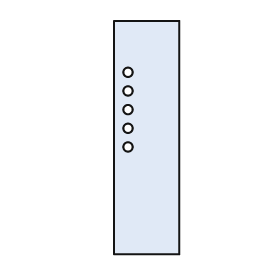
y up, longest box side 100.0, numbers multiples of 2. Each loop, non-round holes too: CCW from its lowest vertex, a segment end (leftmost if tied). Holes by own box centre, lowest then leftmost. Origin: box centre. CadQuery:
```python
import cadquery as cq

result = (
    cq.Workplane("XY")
    .moveTo(-14.0, -50.0)
    .lineTo(14.0, -50.0)
    .lineTo(14.0, 50.0)
    .lineTo(-14.0, 50.0)
    .close()
    .moveTo(-8.0, -4.0)
    .circle(2.0)
    .moveTo(-8.0, 4.0)
    .circle(2.0)
    .moveTo(-8.0, 12.0)
    .circle(2.0)
    .moveTo(-8.0, 20.0)
    .circle(2.0)
    .moveTo(-8.0, 28.0)
    .circle(2.0)
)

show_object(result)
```